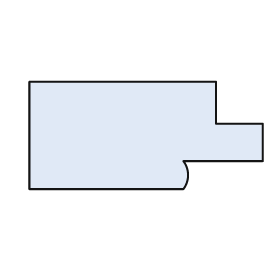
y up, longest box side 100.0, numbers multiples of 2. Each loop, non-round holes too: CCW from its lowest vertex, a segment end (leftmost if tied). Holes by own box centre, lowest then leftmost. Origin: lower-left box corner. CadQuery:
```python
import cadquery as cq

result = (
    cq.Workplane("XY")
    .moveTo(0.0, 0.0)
    .lineTo(66.0, 0.0)
    .threePointArc((68.0, 6.0), (66.0, 12.0))
    .lineTo(100.0, 12.0)
    .lineTo(100.0, 28.0)
    .lineTo(80.0, 28.0)
    .lineTo(80.0, 46.0)
    .lineTo(0.0, 46.0)
    .close()
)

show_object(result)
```